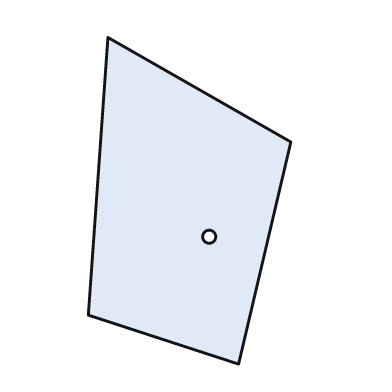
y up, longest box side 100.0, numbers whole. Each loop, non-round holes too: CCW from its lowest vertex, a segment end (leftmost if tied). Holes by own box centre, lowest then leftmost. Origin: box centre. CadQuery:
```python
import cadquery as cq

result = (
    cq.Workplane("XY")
    .moveTo(15.0, -50.0)
    .lineTo(31.0, 18.0)
    .lineTo(-25.0, 50.0)
    .lineTo(-31.0, -35.0)
    .close()
    .moveTo(6.0, -11.0)
    .circle(2.0)
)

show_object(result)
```